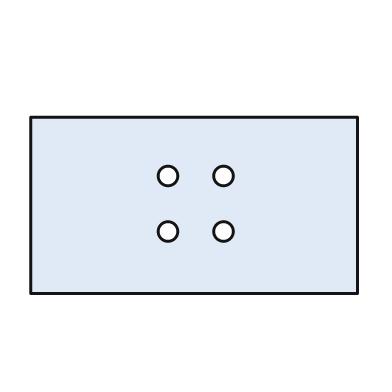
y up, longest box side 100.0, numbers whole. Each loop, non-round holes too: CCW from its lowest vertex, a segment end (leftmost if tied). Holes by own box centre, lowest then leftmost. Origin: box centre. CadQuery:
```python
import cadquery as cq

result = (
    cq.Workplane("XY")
    .moveTo(-50.0, -27.0)
    .lineTo(50.0, -27.0)
    .lineTo(50.0, 27.0)
    .lineTo(-50.0, 27.0)
    .close()
    .moveTo(-8.0, -8.0)
    .circle(3.0)
    .moveTo(9.0, -8.0)
    .circle(3.0)
    .moveTo(-8.0, 9.0)
    .circle(3.0)
    .moveTo(9.0, 9.0)
    .circle(3.0)
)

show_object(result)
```